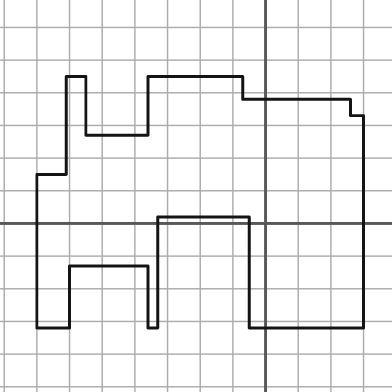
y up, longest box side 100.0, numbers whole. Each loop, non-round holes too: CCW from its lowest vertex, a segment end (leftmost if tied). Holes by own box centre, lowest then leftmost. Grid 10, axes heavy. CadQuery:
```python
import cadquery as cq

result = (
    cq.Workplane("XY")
    .moveTo(-70.0, -32.0)
    .lineTo(-60.0, -32.0)
    .lineTo(-60.0, -13.0)
    .lineTo(-36.0, -13.0)
    .lineTo(-36.0, -32.0)
    .lineTo(-33.0, -32.0)
    .lineTo(-33.0, 2.0)
    .lineTo(-5.0, 2.0)
    .lineTo(-5.0, -32.0)
    .lineTo(30.0, -32.0)
    .lineTo(30.0, 33.0)
    .lineTo(26.0, 33.0)
    .lineTo(26.0, 38.0)
    .lineTo(-7.0, 38.0)
    .lineTo(-7.0, 45.0)
    .lineTo(-36.0, 45.0)
    .lineTo(-36.0, 27.0)
    .lineTo(-55.0, 27.0)
    .lineTo(-55.0, 45.0)
    .lineTo(-61.0, 45.0)
    .lineTo(-61.0, 15.0)
    .lineTo(-70.0, 15.0)
    .close()
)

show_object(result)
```